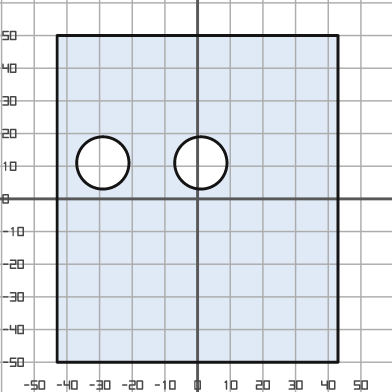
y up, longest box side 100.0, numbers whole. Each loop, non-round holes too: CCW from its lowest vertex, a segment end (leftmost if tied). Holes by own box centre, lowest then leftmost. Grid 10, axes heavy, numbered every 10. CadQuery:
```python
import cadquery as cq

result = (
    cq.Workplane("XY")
    .moveTo(-43.0, -50.0)
    .lineTo(43.0, -50.0)
    .lineTo(43.0, 50.0)
    .lineTo(-43.0, 50.0)
    .close()
    .moveTo(-29.0, 11.0)
    .circle(8.0)
    .moveTo(1.0, 11.0)
    .circle(8.0)
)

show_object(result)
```